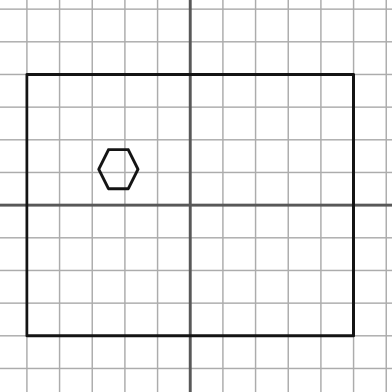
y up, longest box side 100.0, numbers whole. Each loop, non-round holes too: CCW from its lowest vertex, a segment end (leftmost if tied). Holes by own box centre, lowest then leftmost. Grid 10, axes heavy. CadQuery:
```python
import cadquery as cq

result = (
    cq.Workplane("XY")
    .moveTo(-50.0, -40.0)
    .lineTo(50.0, -40.0)
    .lineTo(50.0, 40.0)
    .lineTo(-50.0, 40.0)
    .close()
    .moveTo(-25.0, 5.0)
    .lineTo(-19.0, 5.0)
    .lineTo(-16.0, 11.0)
    .lineTo(-19.0, 17.0)
    .lineTo(-25.0, 17.0)
    .lineTo(-28.0, 11.0)
    .close()
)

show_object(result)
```